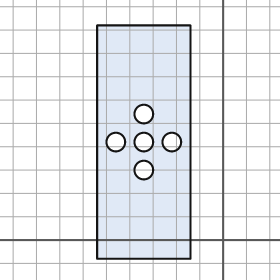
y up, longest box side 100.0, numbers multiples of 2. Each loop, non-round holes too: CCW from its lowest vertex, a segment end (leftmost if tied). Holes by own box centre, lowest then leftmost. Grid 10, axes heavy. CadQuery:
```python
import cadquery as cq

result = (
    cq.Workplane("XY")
    .moveTo(-54.0, -8.0)
    .lineTo(-14.0, -8.0)
    .lineTo(-14.0, 92.0)
    .lineTo(-54.0, 92.0)
    .close()
    .moveTo(-34.0, 30.0)
    .circle(4.0)
    .moveTo(-46.0, 42.0)
    .circle(4.0)
    .moveTo(-34.0, 42.0)
    .circle(4.0)
    .moveTo(-22.0, 42.0)
    .circle(4.0)
    .moveTo(-34.0, 54.0)
    .circle(4.0)
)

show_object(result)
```